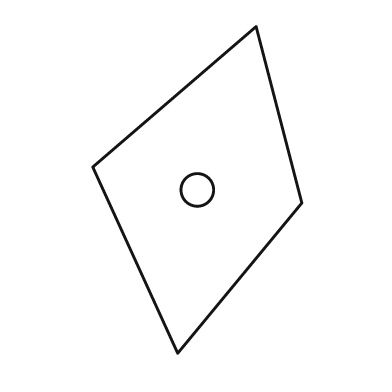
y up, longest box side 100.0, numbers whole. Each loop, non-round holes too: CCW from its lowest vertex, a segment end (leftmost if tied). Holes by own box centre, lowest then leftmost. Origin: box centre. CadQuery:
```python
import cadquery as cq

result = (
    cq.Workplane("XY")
    .moveTo(-6.0, -50.0)
    .lineTo(32.0, -4.0)
    .lineTo(18.0, 50.0)
    .lineTo(-32.0, 7.0)
    .close()
    .moveTo(0.0, 0.0)
    .circle(5.0)
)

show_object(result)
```